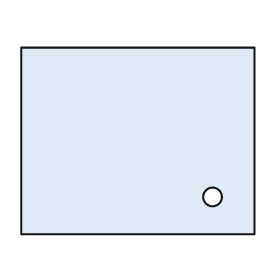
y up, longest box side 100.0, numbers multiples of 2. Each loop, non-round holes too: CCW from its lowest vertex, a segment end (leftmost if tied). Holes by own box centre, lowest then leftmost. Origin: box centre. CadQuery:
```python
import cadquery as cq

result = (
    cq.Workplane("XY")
    .moveTo(-50.0, -40.0)
    .lineTo(50.0, -40.0)
    .lineTo(50.0, 40.0)
    .lineTo(-50.0, 40.0)
    .close()
    .moveTo(32.0, -24.0)
    .circle(4.0)
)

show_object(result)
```